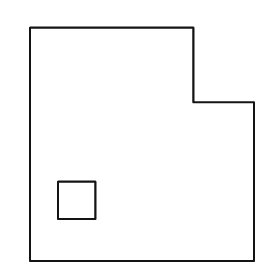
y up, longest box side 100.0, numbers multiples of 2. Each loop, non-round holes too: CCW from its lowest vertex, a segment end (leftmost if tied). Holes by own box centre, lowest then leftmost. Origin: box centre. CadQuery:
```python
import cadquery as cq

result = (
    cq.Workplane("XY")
    .moveTo(-48.0, -50.0)
    .lineTo(48.0, -50.0)
    .lineTo(48.0, 18.0)
    .lineTo(22.0, 18.0)
    .lineTo(22.0, 50.0)
    .lineTo(-48.0, 50.0)
    .close()
    .moveTo(-36.0, -32.0)
    .lineTo(-20.0, -32.0)
    .lineTo(-20.0, -16.0)
    .lineTo(-36.0, -16.0)
    .close()
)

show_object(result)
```